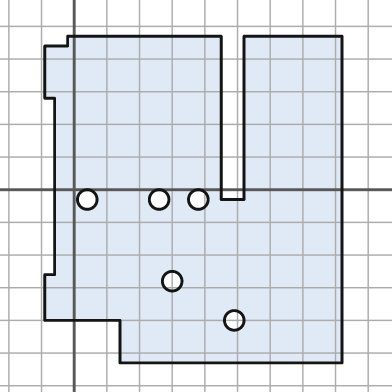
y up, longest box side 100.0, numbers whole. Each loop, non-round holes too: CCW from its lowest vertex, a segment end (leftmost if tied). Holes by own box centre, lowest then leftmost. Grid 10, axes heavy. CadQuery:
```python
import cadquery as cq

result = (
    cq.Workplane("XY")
    .moveTo(14.0, -53.0)
    .lineTo(82.0, -53.0)
    .lineTo(82.0, 47.0)
    .lineTo(52.0, 47.0)
    .lineTo(52.0, -3.0)
    .lineTo(45.0, -3.0)
    .lineTo(45.0, 47.0)
    .lineTo(-2.0, 47.0)
    .lineTo(-2.0, 44.0)
    .lineTo(-9.0, 44.0)
    .lineTo(-9.0, 28.0)
    .lineTo(-6.0, 28.0)
    .lineTo(-6.0, -26.0)
    .lineTo(-9.0, -26.0)
    .lineTo(-9.0, -40.0)
    .lineTo(14.0, -40.0)
    .close()
    .moveTo(49.0, -40.0)
    .circle(3.0)
    .moveTo(30.0, -28.0)
    .circle(3.0)
    .moveTo(4.0, -3.0)
    .circle(3.0)
    .moveTo(26.0, -3.0)
    .circle(3.0)
    .moveTo(38.0, -3.0)
    .circle(3.0)
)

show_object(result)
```